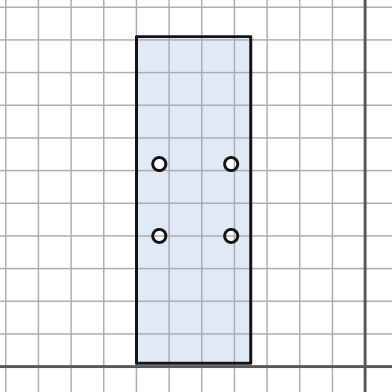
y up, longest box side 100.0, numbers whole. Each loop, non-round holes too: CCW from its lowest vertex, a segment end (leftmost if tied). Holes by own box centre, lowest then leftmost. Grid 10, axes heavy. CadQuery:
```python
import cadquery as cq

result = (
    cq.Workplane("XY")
    .moveTo(-70.0, 1.0)
    .lineTo(-35.0, 1.0)
    .lineTo(-35.0, 101.0)
    .lineTo(-70.0, 101.0)
    .close()
    .moveTo(-63.0, 40.0)
    .circle(2.0)
    .moveTo(-41.0, 40.0)
    .circle(2.0)
    .moveTo(-63.0, 62.0)
    .circle(2.0)
    .moveTo(-41.0, 62.0)
    .circle(2.0)
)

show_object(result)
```